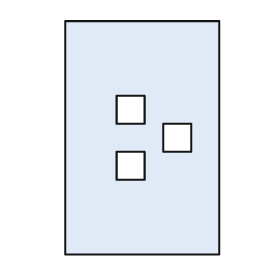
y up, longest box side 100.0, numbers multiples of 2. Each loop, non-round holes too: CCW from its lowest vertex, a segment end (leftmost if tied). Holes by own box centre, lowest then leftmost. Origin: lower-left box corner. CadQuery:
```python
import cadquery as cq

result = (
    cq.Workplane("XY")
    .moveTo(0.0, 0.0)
    .lineTo(66.0, 0.0)
    .lineTo(66.0, 100.0)
    .lineTo(0.0, 100.0)
    .close()
    .moveTo(22.0, 32.0)
    .lineTo(34.0, 32.0)
    .lineTo(34.0, 44.0)
    .lineTo(22.0, 44.0)
    .close()
    .moveTo(42.0, 44.0)
    .lineTo(54.0, 44.0)
    .lineTo(54.0, 56.0)
    .lineTo(42.0, 56.0)
    .close()
    .moveTo(22.0, 56.0)
    .lineTo(34.0, 56.0)
    .lineTo(34.0, 68.0)
    .lineTo(22.0, 68.0)
    .close()
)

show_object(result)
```